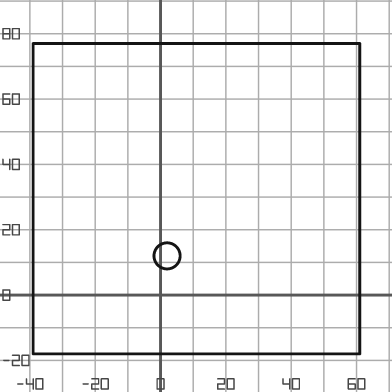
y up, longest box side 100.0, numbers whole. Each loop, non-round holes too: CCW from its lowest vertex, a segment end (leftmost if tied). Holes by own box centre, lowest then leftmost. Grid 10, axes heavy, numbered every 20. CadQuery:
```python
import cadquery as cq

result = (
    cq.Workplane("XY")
    .moveTo(-39.0, -18.0)
    .lineTo(61.0, -18.0)
    .lineTo(61.0, 77.0)
    .lineTo(-39.0, 77.0)
    .close()
    .moveTo(2.0, 12.0)
    .circle(4.0)
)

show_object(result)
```